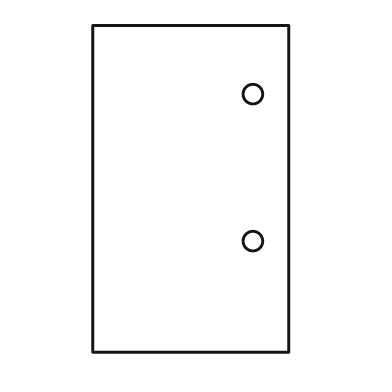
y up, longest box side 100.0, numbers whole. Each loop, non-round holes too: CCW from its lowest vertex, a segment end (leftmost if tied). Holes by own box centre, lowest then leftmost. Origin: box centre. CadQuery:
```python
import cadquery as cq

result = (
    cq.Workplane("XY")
    .moveTo(-30.0, -50.0)
    .lineTo(30.0, -50.0)
    .lineTo(30.0, 50.0)
    .lineTo(-30.0, 50.0)
    .close()
    .moveTo(19.0, -16.0)
    .circle(3.0)
    .moveTo(19.0, 29.0)
    .circle(3.0)
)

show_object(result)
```